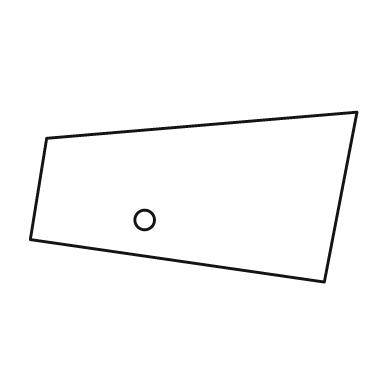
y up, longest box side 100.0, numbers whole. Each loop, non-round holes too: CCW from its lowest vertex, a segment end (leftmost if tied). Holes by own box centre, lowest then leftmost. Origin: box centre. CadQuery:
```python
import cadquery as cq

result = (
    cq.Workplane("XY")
    .moveTo(40.0, -26.0)
    .lineTo(50.0, 26.0)
    .lineTo(-45.0, 18.0)
    .lineTo(-50.0, -13.0)
    .close()
    .moveTo(-15.0, -7.0)
    .circle(3.0)
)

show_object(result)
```